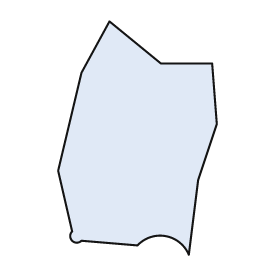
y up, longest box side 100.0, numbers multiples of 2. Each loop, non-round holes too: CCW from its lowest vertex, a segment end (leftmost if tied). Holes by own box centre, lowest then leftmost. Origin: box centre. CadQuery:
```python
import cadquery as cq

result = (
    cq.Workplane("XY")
    .moveTo(22.0, -50.0)
    .lineTo(26.0, -18.0)
    .lineTo(34.0, 6.0)
    .lineTo(32.0, 32.0)
    .lineTo(10.0, 32.0)
    .lineTo(-12.0, 50.0)
    .lineTo(-24.0, 28.0)
    .lineTo(-34.0, -14.0)
    .lineTo(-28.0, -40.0)
    .threePointArc((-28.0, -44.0), (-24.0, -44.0))
    .lineTo(0.0, -46.0)
    .threePointArc((12.0, -42.0), (22.0, -50.0))
    .close()
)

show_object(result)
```